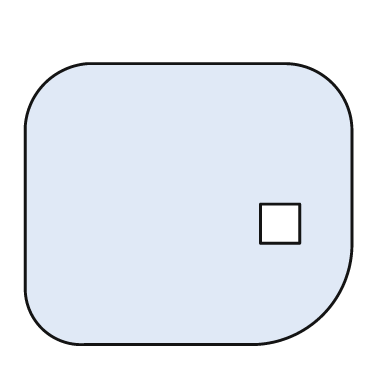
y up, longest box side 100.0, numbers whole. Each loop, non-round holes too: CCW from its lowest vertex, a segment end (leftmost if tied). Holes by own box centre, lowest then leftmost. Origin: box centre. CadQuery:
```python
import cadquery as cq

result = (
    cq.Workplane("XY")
    .moveTo(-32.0, -43.0)
    .lineTo(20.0, -43.0)
    .threePointArc((41.0, -34.0), (50.0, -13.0))
    .lineTo(50.0, 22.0)
    .threePointArc((44.0, 37.0), (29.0, 43.0))
    .lineTo(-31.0, 43.0)
    .threePointArc((-44.0, 37.0), (-50.0, 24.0))
    .lineTo(-50.0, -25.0)
    .threePointArc((-45.0, -38.0), (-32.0, -43.0))
    .close()
    .moveTo(22.0, -12.0)
    .lineTo(34.0, -12.0)
    .lineTo(34.0, 0.0)
    .lineTo(22.0, 0.0)
    .close()
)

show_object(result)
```